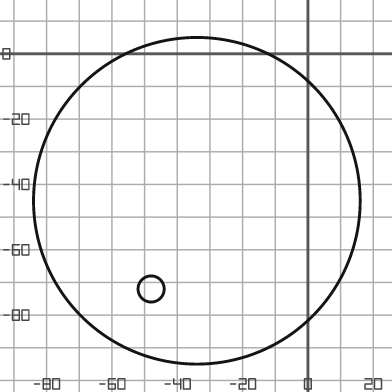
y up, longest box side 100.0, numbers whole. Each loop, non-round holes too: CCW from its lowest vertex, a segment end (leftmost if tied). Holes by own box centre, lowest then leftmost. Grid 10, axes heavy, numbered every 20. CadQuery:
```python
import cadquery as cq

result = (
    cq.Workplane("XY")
    .moveTo(-34.0, -45.0)
    .circle(50.0)
    .moveTo(-48.0, -72.0)
    .circle(4.0)
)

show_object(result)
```